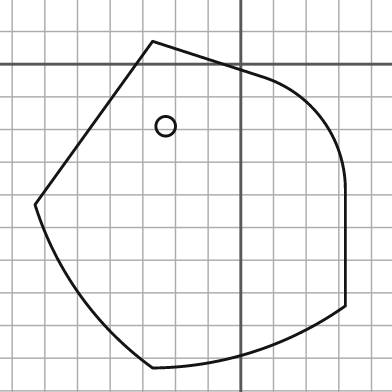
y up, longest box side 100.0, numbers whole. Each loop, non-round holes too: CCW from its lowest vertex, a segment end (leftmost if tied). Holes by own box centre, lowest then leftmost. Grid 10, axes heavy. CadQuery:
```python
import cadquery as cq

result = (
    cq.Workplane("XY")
    .moveTo(-27.0, -93.0)
    .threePointArc((4.0, -88.0), (32.0, -74.0))
    .lineTo(32.0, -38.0)
    .threePointArc((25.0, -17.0), (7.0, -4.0))
    .lineTo(-27.0, 7.0)
    .lineTo(-63.0, -43.0)
    .threePointArc((-49.0, -71.0), (-27.0, -93.0))
    .close()
    .moveTo(-23.0, -19.0)
    .circle(3.0)
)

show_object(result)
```